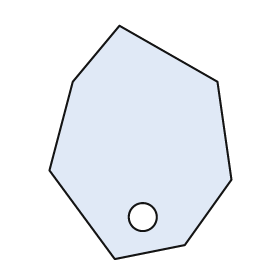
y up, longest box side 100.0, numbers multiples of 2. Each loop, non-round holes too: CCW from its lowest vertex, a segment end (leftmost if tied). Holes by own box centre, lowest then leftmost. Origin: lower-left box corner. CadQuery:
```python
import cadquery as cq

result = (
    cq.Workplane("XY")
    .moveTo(28.0, 0.0)
    .lineTo(58.0, 6.0)
    .lineTo(78.0, 34.0)
    .lineTo(72.0, 76.0)
    .lineTo(30.0, 100.0)
    .lineTo(10.0, 76.0)
    .lineTo(0.0, 38.0)
    .close()
    .moveTo(40.0, 18.0)
    .circle(6.0)
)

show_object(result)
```